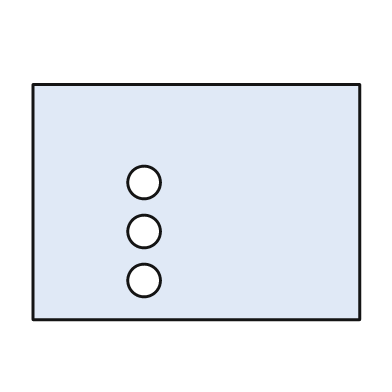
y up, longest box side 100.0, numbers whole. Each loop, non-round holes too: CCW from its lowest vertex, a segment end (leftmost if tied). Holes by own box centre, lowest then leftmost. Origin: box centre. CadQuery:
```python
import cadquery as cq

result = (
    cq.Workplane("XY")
    .moveTo(-50.0, -36.0)
    .lineTo(50.0, -36.0)
    .lineTo(50.0, 36.0)
    .lineTo(-50.0, 36.0)
    .close()
    .moveTo(-16.0, -24.0)
    .circle(5.0)
    .moveTo(-16.0, -9.0)
    .circle(5.0)
    .moveTo(-16.0, 6.0)
    .circle(5.0)
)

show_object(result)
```